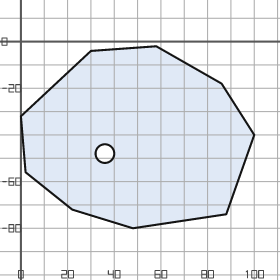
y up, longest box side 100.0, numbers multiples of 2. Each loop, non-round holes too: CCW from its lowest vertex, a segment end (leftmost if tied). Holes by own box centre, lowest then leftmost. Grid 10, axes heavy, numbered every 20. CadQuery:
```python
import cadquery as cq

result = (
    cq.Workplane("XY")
    .moveTo(48.0, -80.0)
    .lineTo(88.0, -74.0)
    .lineTo(100.0, -40.0)
    .lineTo(86.0, -18.0)
    .lineTo(58.0, -2.0)
    .lineTo(30.0, -4.0)
    .lineTo(0.0, -32.0)
    .lineTo(2.0, -56.0)
    .lineTo(22.0, -72.0)
    .close()
    .moveTo(36.0, -48.0)
    .circle(4.0)
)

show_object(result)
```